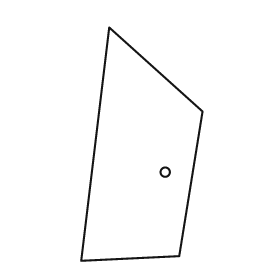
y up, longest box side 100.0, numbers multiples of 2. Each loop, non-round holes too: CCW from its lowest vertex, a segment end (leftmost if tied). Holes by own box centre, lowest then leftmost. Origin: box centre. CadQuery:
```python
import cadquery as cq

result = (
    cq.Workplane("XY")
    .moveTo(-26.0, -50.0)
    .lineTo(16.0, -48.0)
    .lineTo(26.0, 14.0)
    .lineTo(-14.0, 50.0)
    .close()
    .moveTo(10.0, -12.0)
    .circle(2.0)
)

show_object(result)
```